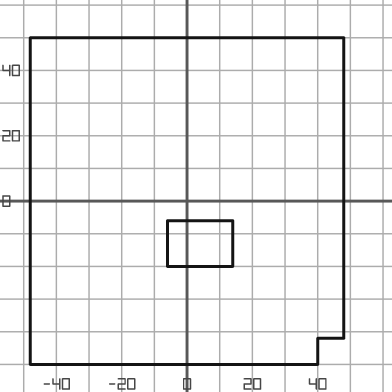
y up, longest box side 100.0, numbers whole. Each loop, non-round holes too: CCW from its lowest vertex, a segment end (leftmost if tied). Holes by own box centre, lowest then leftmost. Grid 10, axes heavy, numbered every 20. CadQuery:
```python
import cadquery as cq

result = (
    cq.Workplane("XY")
    .moveTo(-48.0, -50.0)
    .lineTo(40.0, -50.0)
    .lineTo(40.0, -42.0)
    .lineTo(48.0, -42.0)
    .lineTo(48.0, 50.0)
    .lineTo(-48.0, 50.0)
    .close()
    .moveTo(-6.0, -20.0)
    .lineTo(14.0, -20.0)
    .lineTo(14.0, -6.0)
    .lineTo(-6.0, -6.0)
    .close()
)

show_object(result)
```